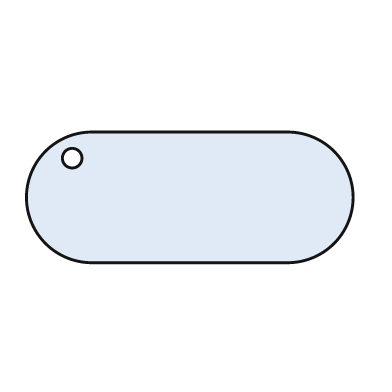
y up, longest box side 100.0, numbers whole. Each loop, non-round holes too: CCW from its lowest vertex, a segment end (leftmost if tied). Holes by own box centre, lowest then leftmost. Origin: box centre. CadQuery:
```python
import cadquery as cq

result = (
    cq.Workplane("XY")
    .moveTo(-30.0, -20.0)
    .lineTo(30.0, -20.0)
    .threePointArc((50.0, 0.0), (30.0, 20.0))
    .lineTo(-30.0, 20.0)
    .threePointArc((-50.0, 0.0), (-30.0, -20.0))
    .close()
    .moveTo(-36.0, 12.0)
    .circle(3.0)
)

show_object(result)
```